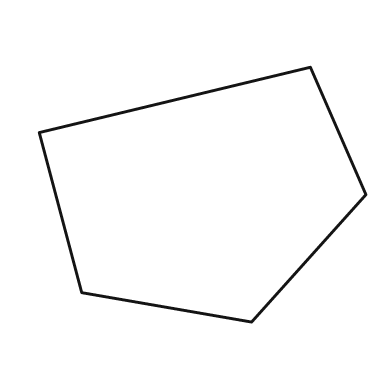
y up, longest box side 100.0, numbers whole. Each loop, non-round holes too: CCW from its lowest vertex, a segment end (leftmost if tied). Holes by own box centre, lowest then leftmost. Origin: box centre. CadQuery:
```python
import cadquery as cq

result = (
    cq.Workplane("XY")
    .moveTo(15.0, -39.0)
    .lineTo(50.0, 0.0)
    .lineTo(33.0, 39.0)
    .lineTo(-50.0, 19.0)
    .lineTo(-37.0, -30.0)
    .close()
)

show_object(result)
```